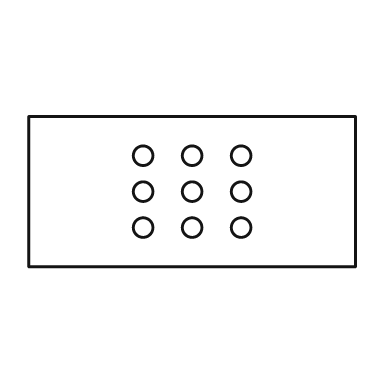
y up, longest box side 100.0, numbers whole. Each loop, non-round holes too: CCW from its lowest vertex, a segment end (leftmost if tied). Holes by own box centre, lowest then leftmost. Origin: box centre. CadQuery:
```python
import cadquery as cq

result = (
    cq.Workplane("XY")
    .moveTo(-50.0, -23.0)
    .lineTo(50.0, -23.0)
    .lineTo(50.0, 23.0)
    .lineTo(-50.0, 23.0)
    .close()
    .moveTo(-15.0, -11.0)
    .circle(3.0)
    .moveTo(0.0, -11.0)
    .circle(3.0)
    .moveTo(15.0, -11.0)
    .circle(3.0)
    .moveTo(-15.0, 0.0)
    .circle(3.0)
    .moveTo(0.0, 0.0)
    .circle(3.0)
    .moveTo(15.0, 0.0)
    .circle(3.0)
    .moveTo(-15.0, 11.0)
    .circle(3.0)
    .moveTo(0.0, 11.0)
    .circle(3.0)
    .moveTo(15.0, 11.0)
    .circle(3.0)
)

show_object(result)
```